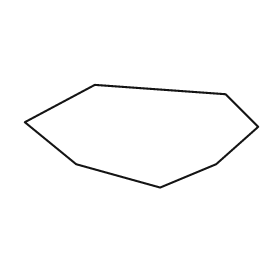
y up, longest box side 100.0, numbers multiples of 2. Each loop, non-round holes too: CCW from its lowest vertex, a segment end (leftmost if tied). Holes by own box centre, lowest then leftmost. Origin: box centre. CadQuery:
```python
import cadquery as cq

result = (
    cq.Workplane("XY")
    .moveTo(8.0, -22.0)
    .lineTo(32.0, -12.0)
    .lineTo(50.0, 4.0)
    .lineTo(36.0, 18.0)
    .lineTo(-20.0, 22.0)
    .lineTo(-50.0, 6.0)
    .lineTo(-28.0, -12.0)
    .close()
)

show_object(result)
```